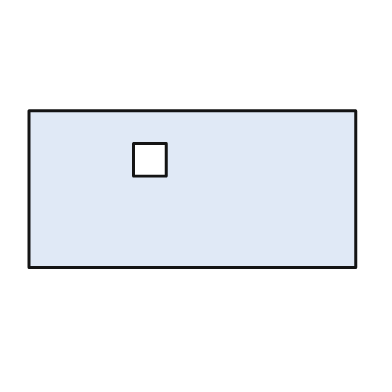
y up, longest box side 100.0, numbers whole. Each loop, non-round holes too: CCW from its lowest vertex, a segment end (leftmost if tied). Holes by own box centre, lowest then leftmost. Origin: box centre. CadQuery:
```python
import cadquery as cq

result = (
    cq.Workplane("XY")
    .moveTo(-50.0, -24.0)
    .lineTo(50.0, -24.0)
    .lineTo(50.0, 24.0)
    .lineTo(-50.0, 24.0)
    .close()
    .moveTo(-18.0, 4.0)
    .lineTo(-8.0, 4.0)
    .lineTo(-8.0, 14.0)
    .lineTo(-18.0, 14.0)
    .close()
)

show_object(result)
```